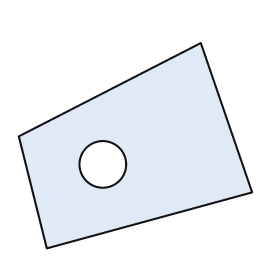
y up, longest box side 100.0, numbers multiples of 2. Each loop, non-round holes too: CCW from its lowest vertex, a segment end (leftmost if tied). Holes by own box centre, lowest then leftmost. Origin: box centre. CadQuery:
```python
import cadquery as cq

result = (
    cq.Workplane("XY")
    .moveTo(-38.0, -44.0)
    .lineTo(50.0, -20.0)
    .lineTo(28.0, 44.0)
    .lineTo(-50.0, 4.0)
    .close()
    .moveTo(-14.0, -8.0)
    .circle(10.0)
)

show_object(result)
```